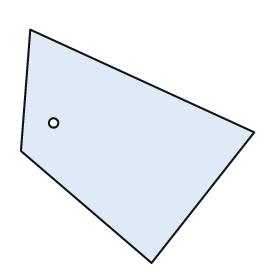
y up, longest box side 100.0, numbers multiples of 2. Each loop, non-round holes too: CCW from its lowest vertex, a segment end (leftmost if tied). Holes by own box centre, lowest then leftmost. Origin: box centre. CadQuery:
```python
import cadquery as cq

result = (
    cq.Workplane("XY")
    .moveTo(6.0, -50.0)
    .lineTo(50.0, 6.0)
    .lineTo(-46.0, 50.0)
    .lineTo(-50.0, -2.0)
    .close()
    .moveTo(-36.0, 10.0)
    .circle(2.0)
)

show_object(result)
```